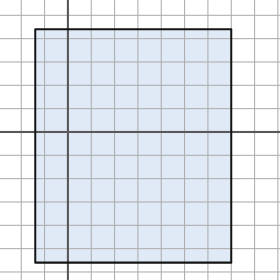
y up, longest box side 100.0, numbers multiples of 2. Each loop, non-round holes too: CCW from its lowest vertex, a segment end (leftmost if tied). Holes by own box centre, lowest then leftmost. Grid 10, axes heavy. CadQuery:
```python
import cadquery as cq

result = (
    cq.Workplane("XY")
    .moveTo(-14.0, -56.0)
    .lineTo(70.0, -56.0)
    .lineTo(70.0, 44.0)
    .lineTo(-14.0, 44.0)
    .close()
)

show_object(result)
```